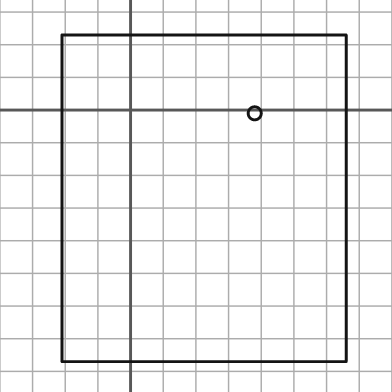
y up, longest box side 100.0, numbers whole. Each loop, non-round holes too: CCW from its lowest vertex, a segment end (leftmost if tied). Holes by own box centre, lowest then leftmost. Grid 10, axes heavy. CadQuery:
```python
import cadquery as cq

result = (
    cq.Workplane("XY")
    .moveTo(-21.0, -77.0)
    .lineTo(66.0, -77.0)
    .lineTo(66.0, 23.0)
    .lineTo(-21.0, 23.0)
    .close()
    .moveTo(38.0, -1.0)
    .circle(2.0)
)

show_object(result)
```